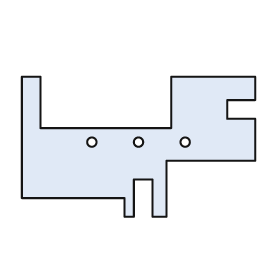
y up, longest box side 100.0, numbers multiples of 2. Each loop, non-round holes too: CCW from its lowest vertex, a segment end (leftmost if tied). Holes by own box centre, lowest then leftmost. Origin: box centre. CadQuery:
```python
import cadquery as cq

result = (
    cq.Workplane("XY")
    .moveTo(-6.0, -30.0)
    .lineTo(-2.0, -30.0)
    .lineTo(-2.0, -14.0)
    .lineTo(6.0, -14.0)
    .lineTo(6.0, -30.0)
    .lineTo(12.0, -30.0)
    .lineTo(12.0, -6.0)
    .lineTo(50.0, -6.0)
    .lineTo(50.0, 12.0)
    .lineTo(38.0, 12.0)
    .lineTo(38.0, 20.0)
    .lineTo(50.0, 20.0)
    .lineTo(50.0, 30.0)
    .lineTo(14.0, 30.0)
    .lineTo(14.0, 8.0)
    .lineTo(-42.0, 8.0)
    .lineTo(-42.0, 30.0)
    .lineTo(-50.0, 30.0)
    .lineTo(-50.0, -22.0)
    .lineTo(-6.0, -22.0)
    .close()
    .moveTo(-20.0, 2.0)
    .circle(2.0)
    .moveTo(0.0, 2.0)
    .circle(2.0)
    .moveTo(20.0, 2.0)
    .circle(2.0)
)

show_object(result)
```